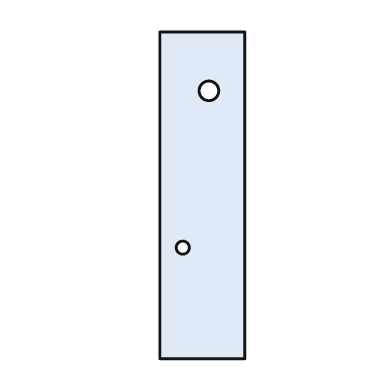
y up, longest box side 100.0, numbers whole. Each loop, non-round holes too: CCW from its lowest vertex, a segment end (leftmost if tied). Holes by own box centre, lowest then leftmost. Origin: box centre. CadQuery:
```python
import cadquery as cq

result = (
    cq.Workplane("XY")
    .moveTo(-13.0, -50.0)
    .lineTo(13.0, -50.0)
    .lineTo(13.0, 50.0)
    .lineTo(-13.0, 50.0)
    .close()
    .moveTo(-6.0, -16.0)
    .circle(2.0)
    .moveTo(2.0, 32.0)
    .circle(3.0)
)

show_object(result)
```